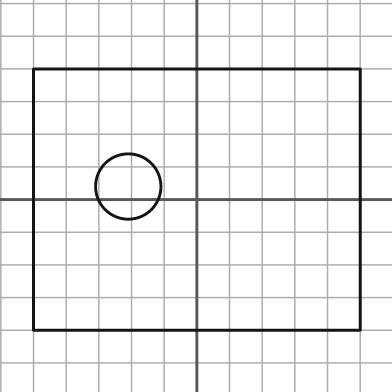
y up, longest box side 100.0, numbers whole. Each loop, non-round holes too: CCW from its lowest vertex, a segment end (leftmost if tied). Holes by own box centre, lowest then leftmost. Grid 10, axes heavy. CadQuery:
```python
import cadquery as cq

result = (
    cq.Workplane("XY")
    .moveTo(-50.0, -40.0)
    .lineTo(50.0, -40.0)
    .lineTo(50.0, 40.0)
    .lineTo(-50.0, 40.0)
    .close()
    .moveTo(-21.0, 4.0)
    .circle(10.0)
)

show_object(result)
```